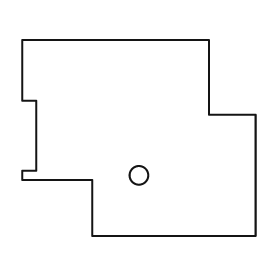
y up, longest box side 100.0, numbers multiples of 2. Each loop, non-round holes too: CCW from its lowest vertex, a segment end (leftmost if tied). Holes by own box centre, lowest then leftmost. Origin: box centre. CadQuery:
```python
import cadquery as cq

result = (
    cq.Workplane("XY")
    .moveTo(-20.0, -42.0)
    .lineTo(50.0, -42.0)
    .lineTo(50.0, 10.0)
    .lineTo(30.0, 10.0)
    .lineTo(30.0, 42.0)
    .lineTo(-50.0, 42.0)
    .lineTo(-50.0, 16.0)
    .lineTo(-44.0, 16.0)
    .lineTo(-44.0, -14.0)
    .lineTo(-50.0, -14.0)
    .lineTo(-50.0, -18.0)
    .lineTo(-20.0, -18.0)
    .close()
    .moveTo(0.0, -16.0)
    .circle(4.0)
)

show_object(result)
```